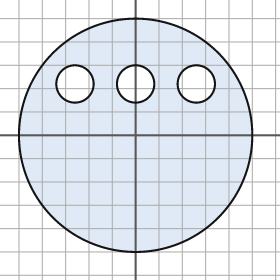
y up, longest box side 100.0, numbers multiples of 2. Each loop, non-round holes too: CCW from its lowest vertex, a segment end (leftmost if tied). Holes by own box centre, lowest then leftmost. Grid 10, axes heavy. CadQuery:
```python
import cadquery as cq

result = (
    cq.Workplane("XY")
    .moveTo(0.0, 0.0)
    .circle(50.0)
    .moveTo(-26.0, 22.0)
    .circle(8.0)
    .moveTo(0.0, 22.0)
    .circle(8.0)
    .moveTo(26.0, 22.0)
    .circle(8.0)
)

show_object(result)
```